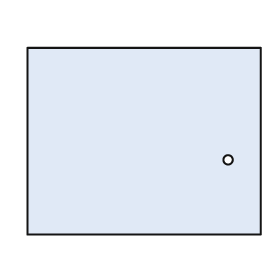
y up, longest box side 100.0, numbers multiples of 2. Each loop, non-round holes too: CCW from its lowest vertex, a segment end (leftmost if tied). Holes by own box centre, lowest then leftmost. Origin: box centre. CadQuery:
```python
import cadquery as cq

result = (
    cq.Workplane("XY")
    .moveTo(-50.0, -40.0)
    .lineTo(50.0, -40.0)
    .lineTo(50.0, 40.0)
    .lineTo(-50.0, 40.0)
    .close()
    .moveTo(36.0, -8.0)
    .circle(2.0)
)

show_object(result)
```